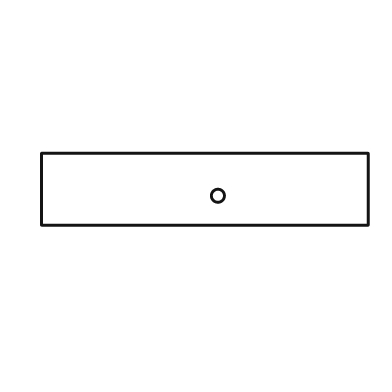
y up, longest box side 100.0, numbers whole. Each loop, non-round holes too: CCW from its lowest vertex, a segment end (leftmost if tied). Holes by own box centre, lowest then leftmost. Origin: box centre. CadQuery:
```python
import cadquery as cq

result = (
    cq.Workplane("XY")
    .moveTo(-50.0, -11.0)
    .lineTo(50.0, -11.0)
    .lineTo(50.0, 11.0)
    .lineTo(-50.0, 11.0)
    .close()
    .moveTo(4.0, -2.0)
    .circle(2.0)
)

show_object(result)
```